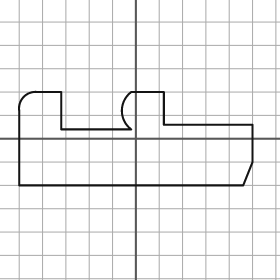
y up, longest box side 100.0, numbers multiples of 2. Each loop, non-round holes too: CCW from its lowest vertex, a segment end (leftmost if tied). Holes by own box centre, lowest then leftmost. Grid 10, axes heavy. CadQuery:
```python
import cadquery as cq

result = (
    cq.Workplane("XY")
    .moveTo(-50.0, -20.0)
    .lineTo(46.0, -20.0)
    .lineTo(50.0, -10.0)
    .lineTo(50.0, 6.0)
    .lineTo(12.0, 6.0)
    .lineTo(12.0, 20.0)
    .lineTo(-2.0, 20.0)
    .threePointArc((-6.0, 12.0), (-2.0, 4.0))
    .lineTo(-32.0, 4.0)
    .lineTo(-32.0, 20.0)
    .lineTo(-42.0, 20.0)
    .threePointArc((-48.0, 18.0), (-50.0, 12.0))
    .close()
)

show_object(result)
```